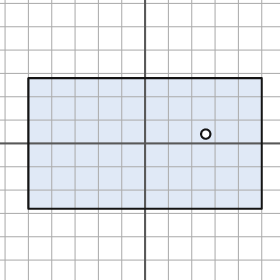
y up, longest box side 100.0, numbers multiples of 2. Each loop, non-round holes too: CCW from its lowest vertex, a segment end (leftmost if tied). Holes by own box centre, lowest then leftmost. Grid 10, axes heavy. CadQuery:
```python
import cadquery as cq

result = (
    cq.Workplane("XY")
    .moveTo(-50.0, -28.0)
    .lineTo(50.0, -28.0)
    .lineTo(50.0, 28.0)
    .lineTo(-50.0, 28.0)
    .close()
    .moveTo(26.0, 4.0)
    .circle(2.0)
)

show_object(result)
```